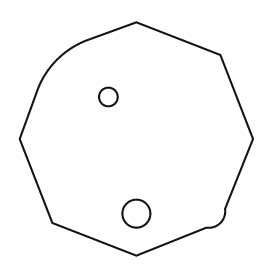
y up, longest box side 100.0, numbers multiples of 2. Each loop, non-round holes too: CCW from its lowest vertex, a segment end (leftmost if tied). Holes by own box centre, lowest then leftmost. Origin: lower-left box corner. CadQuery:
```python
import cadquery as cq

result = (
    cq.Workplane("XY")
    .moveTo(50.0, 0.0)
    .lineTo(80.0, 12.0)
    .threePointArc((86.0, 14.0), (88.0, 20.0))
    .lineTo(100.0, 50.0)
    .lineTo(86.0, 86.0)
    .lineTo(50.0, 100.0)
    .lineTo(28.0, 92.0)
    .threePointArc((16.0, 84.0), (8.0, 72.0))
    .lineTo(0.0, 50.0)
    .lineTo(14.0, 14.0)
    .close()
    .moveTo(50.0, 18.0)
    .circle(6.0)
    .moveTo(38.0, 68.0)
    .circle(4.0)
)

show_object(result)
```